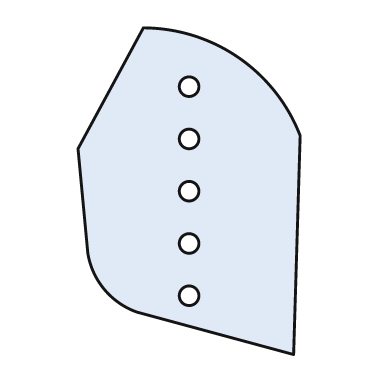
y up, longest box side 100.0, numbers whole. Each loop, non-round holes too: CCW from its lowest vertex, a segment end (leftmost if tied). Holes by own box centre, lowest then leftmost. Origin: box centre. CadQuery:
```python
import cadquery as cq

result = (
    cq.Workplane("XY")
    .moveTo(32.0, -50.0)
    .lineTo(34.0, 17.0)
    .threePointArc((15.0, 41.0), (-14.0, 50.0))
    .lineTo(-34.0, 13.0)
    .lineTo(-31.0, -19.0)
    .threePointArc((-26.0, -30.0), (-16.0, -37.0))
    .close()
    .moveTo(0.0, -32.0)
    .circle(3.0)
    .moveTo(0.0, -16.0)
    .circle(3.0)
    .moveTo(0.0, 0.0)
    .circle(3.0)
    .moveTo(0.0, 16.0)
    .circle(3.0)
    .moveTo(0.0, 32.0)
    .circle(3.0)
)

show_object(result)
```